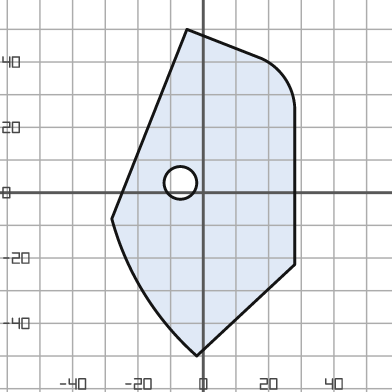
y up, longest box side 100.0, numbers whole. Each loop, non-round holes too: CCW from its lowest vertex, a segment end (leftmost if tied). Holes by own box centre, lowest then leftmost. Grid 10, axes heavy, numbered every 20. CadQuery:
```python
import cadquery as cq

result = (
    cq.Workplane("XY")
    .moveTo(-2.0, -50.0)
    .lineTo(28.0, -22.0)
    .lineTo(28.0, 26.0)
    .threePointArc((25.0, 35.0), (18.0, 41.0))
    .lineTo(-5.0, 50.0)
    .lineTo(-28.0, -8.0)
    .threePointArc((-18.0, -31.0), (-2.0, -50.0))
    .close()
    .moveTo(-7.0, 3.0)
    .circle(5.0)
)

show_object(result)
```